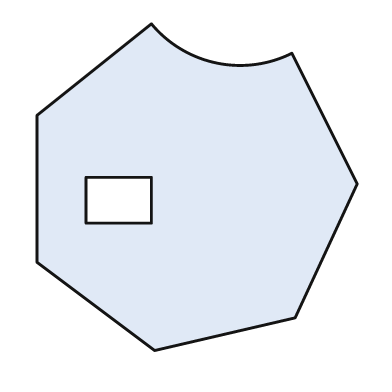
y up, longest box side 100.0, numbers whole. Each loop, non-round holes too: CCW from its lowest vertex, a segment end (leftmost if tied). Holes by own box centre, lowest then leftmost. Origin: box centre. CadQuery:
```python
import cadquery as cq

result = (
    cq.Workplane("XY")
    .moveTo(-13.0, -50.0)
    .lineTo(30.0, -40.0)
    .lineTo(49.0, 1.0)
    .lineTo(29.0, 41.0)
    .threePointArc((6.0, 38.0), (-14.0, 50.0))
    .lineTo(-49.0, 22.0)
    .lineTo(-49.0, -23.0)
    .close()
    .moveTo(-34.0, -11.0)
    .lineTo(-14.0, -11.0)
    .lineTo(-14.0, 3.0)
    .lineTo(-34.0, 3.0)
    .close()
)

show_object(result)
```